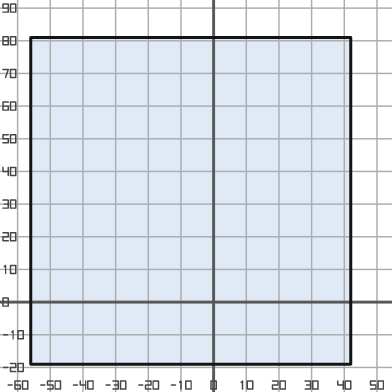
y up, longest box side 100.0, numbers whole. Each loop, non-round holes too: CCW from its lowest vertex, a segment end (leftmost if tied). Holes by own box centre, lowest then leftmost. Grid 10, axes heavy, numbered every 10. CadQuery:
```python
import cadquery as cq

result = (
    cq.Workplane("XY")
    .moveTo(-56.0, -19.0)
    .lineTo(42.0, -19.0)
    .lineTo(42.0, 81.0)
    .lineTo(-56.0, 81.0)
    .close()
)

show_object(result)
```